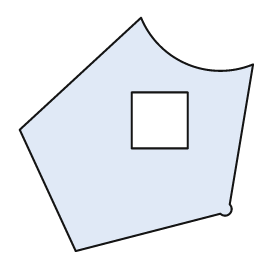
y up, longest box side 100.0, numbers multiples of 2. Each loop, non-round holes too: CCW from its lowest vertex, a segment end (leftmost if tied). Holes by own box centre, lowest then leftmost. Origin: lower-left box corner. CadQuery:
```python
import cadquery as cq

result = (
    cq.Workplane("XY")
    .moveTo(24.0, 0.0)
    .lineTo(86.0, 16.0)
    .threePointArc((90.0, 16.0), (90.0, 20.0))
    .lineTo(100.0, 80.0)
    .threePointArc((72.0, 80.0), (52.0, 100.0))
    .lineTo(0.0, 52.0)
    .close()
    .moveTo(48.0, 44.0)
    .lineTo(72.0, 44.0)
    .lineTo(72.0, 68.0)
    .lineTo(48.0, 68.0)
    .close()
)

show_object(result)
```